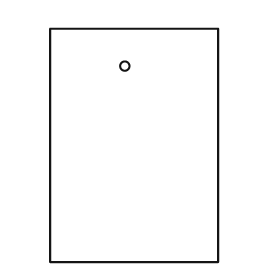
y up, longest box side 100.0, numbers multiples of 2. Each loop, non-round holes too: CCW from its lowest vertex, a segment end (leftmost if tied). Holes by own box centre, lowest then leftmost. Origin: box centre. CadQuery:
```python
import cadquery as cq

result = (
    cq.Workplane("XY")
    .moveTo(-36.0, -50.0)
    .lineTo(36.0, -50.0)
    .lineTo(36.0, 50.0)
    .lineTo(-36.0, 50.0)
    .close()
    .moveTo(-4.0, 34.0)
    .circle(2.0)
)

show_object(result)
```